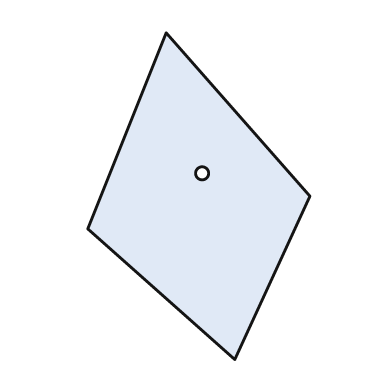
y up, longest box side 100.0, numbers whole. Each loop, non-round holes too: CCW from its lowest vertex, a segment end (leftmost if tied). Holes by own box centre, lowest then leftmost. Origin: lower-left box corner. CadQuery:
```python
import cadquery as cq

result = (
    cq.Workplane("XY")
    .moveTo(45.0, 0.0)
    .lineTo(68.0, 50.0)
    .lineTo(24.0, 100.0)
    .lineTo(0.0, 40.0)
    .close()
    .moveTo(35.0, 57.0)
    .circle(2.0)
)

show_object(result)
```